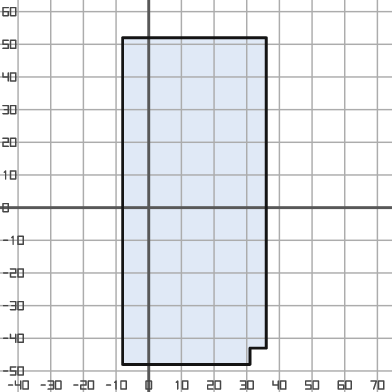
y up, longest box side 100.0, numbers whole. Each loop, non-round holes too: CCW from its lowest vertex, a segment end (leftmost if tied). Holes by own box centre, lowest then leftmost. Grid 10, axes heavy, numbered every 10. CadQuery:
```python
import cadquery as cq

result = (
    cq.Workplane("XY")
    .moveTo(-8.0, -48.0)
    .lineTo(31.0, -48.0)
    .lineTo(31.0, -43.0)
    .lineTo(36.0, -43.0)
    .lineTo(36.0, 52.0)
    .lineTo(-8.0, 52.0)
    .close()
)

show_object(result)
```